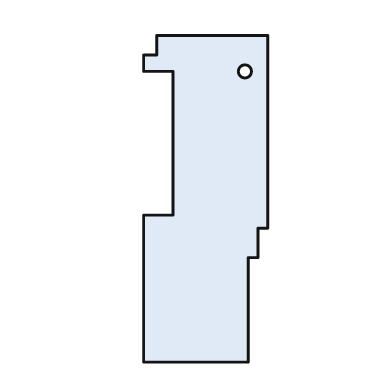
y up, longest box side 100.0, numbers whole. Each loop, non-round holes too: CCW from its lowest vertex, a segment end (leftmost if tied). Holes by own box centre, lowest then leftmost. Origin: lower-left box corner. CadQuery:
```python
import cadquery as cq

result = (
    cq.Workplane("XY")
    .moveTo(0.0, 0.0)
    .lineTo(32.0, 0.0)
    .lineTo(32.0, 32.0)
    .lineTo(35.0, 32.0)
    .lineTo(35.0, 41.0)
    .lineTo(38.0, 41.0)
    .lineTo(38.0, 100.0)
    .lineTo(4.0, 100.0)
    .lineTo(4.0, 94.0)
    .lineTo(0.0, 94.0)
    .lineTo(0.0, 89.0)
    .lineTo(9.0, 89.0)
    .lineTo(9.0, 45.0)
    .lineTo(0.0, 45.0)
    .close()
    .moveTo(31.0, 89.0)
    .circle(2.0)
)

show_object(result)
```